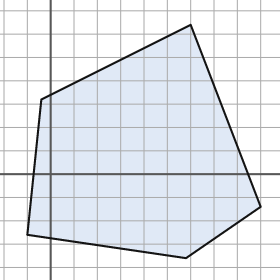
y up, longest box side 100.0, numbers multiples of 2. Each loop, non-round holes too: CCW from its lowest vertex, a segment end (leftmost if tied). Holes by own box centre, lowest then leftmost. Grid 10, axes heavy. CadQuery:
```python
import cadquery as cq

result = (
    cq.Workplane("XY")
    .moveTo(58.0, -36.0)
    .lineTo(90.0, -14.0)
    .lineTo(60.0, 64.0)
    .lineTo(-4.0, 32.0)
    .lineTo(-10.0, -26.0)
    .close()
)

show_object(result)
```